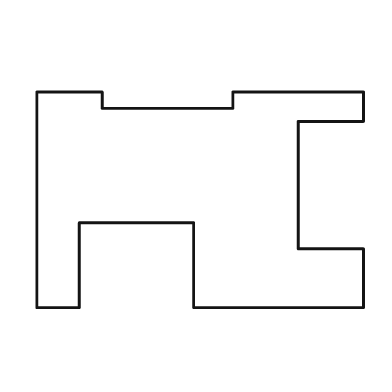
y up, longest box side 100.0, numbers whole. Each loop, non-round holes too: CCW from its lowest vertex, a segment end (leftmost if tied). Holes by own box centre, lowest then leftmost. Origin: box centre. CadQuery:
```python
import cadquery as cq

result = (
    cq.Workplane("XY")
    .moveTo(-50.0, -33.0)
    .lineTo(-37.0, -33.0)
    .lineTo(-37.0, -7.0)
    .lineTo(-2.0, -7.0)
    .lineTo(-2.0, -33.0)
    .lineTo(50.0, -33.0)
    .lineTo(50.0, -15.0)
    .lineTo(30.0, -15.0)
    .lineTo(30.0, 24.0)
    .lineTo(50.0, 24.0)
    .lineTo(50.0, 33.0)
    .lineTo(10.0, 33.0)
    .lineTo(10.0, 28.0)
    .lineTo(-30.0, 28.0)
    .lineTo(-30.0, 33.0)
    .lineTo(-50.0, 33.0)
    .close()
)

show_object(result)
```